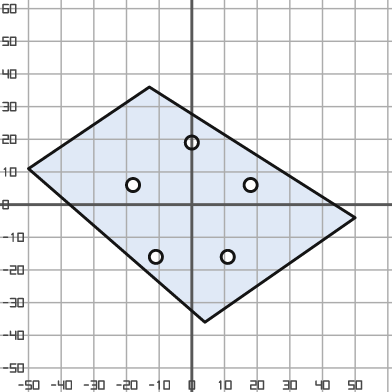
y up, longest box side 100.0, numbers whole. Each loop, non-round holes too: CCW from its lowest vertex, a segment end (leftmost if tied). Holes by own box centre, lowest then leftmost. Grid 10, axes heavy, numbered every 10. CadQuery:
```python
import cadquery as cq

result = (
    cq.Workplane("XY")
    .moveTo(4.0, -36.0)
    .lineTo(50.0, -4.0)
    .lineTo(-13.0, 36.0)
    .lineTo(-50.0, 11.0)
    .close()
    .moveTo(-11.0, -16.0)
    .circle(2.0)
    .moveTo(11.0, -16.0)
    .circle(2.0)
    .moveTo(-18.0, 6.0)
    .circle(2.0)
    .moveTo(18.0, 6.0)
    .circle(2.0)
    .moveTo(0.0, 19.0)
    .circle(2.0)
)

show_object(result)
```